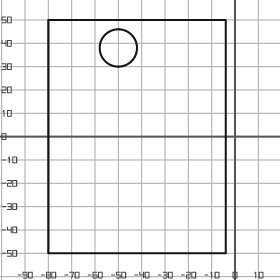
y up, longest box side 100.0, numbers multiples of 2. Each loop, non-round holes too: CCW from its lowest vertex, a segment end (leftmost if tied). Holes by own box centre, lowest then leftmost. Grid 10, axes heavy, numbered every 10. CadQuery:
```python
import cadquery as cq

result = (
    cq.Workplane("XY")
    .moveTo(-80.0, -50.0)
    .lineTo(-4.0, -50.0)
    .lineTo(-4.0, 50.0)
    .lineTo(-80.0, 50.0)
    .close()
    .moveTo(-50.0, 38.0)
    .circle(8.0)
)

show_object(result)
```